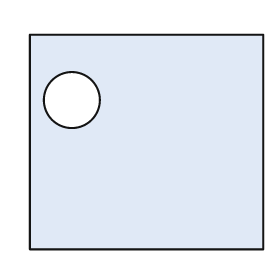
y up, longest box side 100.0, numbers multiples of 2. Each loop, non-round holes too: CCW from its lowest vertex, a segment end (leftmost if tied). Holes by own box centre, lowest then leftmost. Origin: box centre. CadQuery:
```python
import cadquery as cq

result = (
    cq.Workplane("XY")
    .moveTo(-50.0, -46.0)
    .lineTo(50.0, -46.0)
    .lineTo(50.0, 46.0)
    .lineTo(-50.0, 46.0)
    .close()
    .moveTo(-32.0, 18.0)
    .circle(12.0)
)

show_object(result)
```